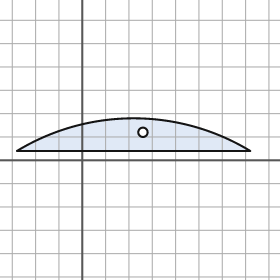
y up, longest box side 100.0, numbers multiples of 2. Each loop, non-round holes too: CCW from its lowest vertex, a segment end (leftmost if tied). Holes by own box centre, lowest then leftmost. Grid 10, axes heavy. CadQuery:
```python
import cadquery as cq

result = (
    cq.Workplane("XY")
    .moveTo(-28.0, 4.0)
    .lineTo(72.0, 4.0)
    .threePointArc((22.0, 18.0), (-28.0, 4.0))
    .close()
    .moveTo(26.0, 12.0)
    .circle(2.0)
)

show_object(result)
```